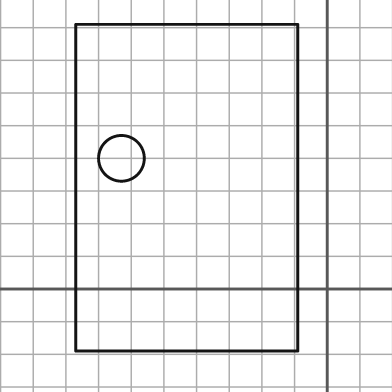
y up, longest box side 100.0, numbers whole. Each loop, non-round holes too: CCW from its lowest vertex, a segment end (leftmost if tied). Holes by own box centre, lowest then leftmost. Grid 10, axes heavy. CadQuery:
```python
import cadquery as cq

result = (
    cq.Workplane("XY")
    .moveTo(-77.0, -19.0)
    .lineTo(-9.0, -19.0)
    .lineTo(-9.0, 81.0)
    .lineTo(-77.0, 81.0)
    .close()
    .moveTo(-63.0, 40.0)
    .circle(7.0)
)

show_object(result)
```